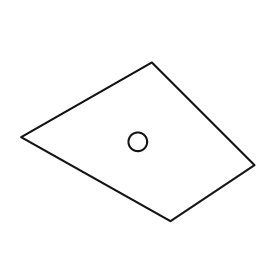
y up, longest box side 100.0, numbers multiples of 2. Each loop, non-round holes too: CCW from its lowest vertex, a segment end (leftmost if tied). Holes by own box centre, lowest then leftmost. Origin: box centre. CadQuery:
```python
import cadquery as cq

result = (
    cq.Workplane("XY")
    .moveTo(14.0, -34.0)
    .lineTo(50.0, -10.0)
    .lineTo(6.0, 34.0)
    .lineTo(-50.0, 2.0)
    .close()
    .moveTo(0.0, 0.0)
    .circle(4.0)
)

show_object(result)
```